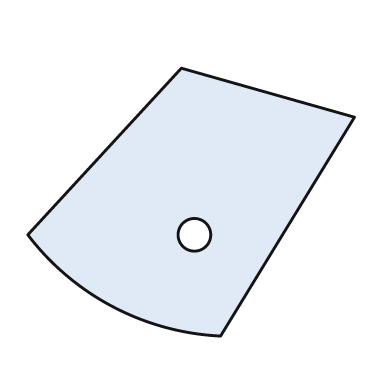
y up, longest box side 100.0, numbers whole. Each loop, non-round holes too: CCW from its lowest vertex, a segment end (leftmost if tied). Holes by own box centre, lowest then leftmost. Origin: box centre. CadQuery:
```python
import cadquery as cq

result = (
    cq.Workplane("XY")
    .moveTo(9.0, -41.0)
    .lineTo(50.0, 26.0)
    .lineTo(-3.0, 41.0)
    .lineTo(-50.0, -10.0)
    .threePointArc((-24.0, -32.0), (9.0, -41.0))
    .close()
    .moveTo(1.0, -10.0)
    .circle(5.0)
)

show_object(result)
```